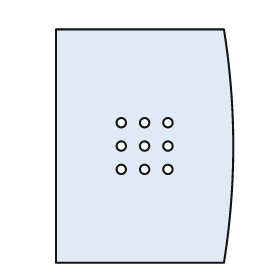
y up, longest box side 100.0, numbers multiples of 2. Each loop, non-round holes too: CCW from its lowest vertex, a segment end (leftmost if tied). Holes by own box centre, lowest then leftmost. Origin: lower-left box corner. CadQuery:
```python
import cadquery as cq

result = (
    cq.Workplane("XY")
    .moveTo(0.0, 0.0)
    .lineTo(72.0, 0.0)
    .threePointArc((76.0, 50.0), (72.0, 100.0))
    .lineTo(0.0, 100.0)
    .close()
    .moveTo(28.0, 40.0)
    .circle(2.0)
    .moveTo(38.0, 40.0)
    .circle(2.0)
    .moveTo(48.0, 40.0)
    .circle(2.0)
    .moveTo(28.0, 50.0)
    .circle(2.0)
    .moveTo(38.0, 50.0)
    .circle(2.0)
    .moveTo(48.0, 50.0)
    .circle(2.0)
    .moveTo(28.0, 60.0)
    .circle(2.0)
    .moveTo(38.0, 60.0)
    .circle(2.0)
    .moveTo(48.0, 60.0)
    .circle(2.0)
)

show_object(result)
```